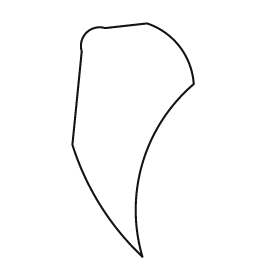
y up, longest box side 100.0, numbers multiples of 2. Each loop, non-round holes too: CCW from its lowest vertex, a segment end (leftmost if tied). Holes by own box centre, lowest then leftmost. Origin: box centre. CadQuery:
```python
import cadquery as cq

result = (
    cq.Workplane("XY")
    .moveTo(4.0, -50.0)
    .threePointArc((4.0, -10.0), (26.0, 24.0))
    .threePointArc((20.0, 40.0), (6.0, 50.0))
    .lineTo(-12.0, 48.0)
    .threePointArc((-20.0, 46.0), (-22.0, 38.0))
    .lineTo(-26.0, -2.0)
    .threePointArc((-14.0, -28.0), (4.0, -50.0))
    .close()
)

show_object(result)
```